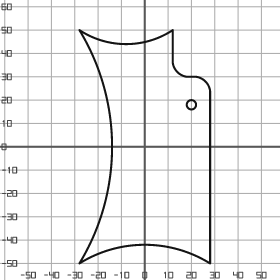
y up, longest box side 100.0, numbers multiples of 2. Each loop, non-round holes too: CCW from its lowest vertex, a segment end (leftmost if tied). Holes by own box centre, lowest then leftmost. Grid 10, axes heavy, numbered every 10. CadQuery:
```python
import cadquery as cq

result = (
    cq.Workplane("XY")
    .moveTo(-28.0, -50.0)
    .threePointArc((0.0, -42.0), (28.0, -50.0))
    .lineTo(28.0, 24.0)
    .threePointArc((26.0, 28.0), (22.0, 30.0))
    .lineTo(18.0, 30.0)
    .threePointArc((14.0, 32.0), (12.0, 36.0))
    .lineTo(12.0, 50.0)
    .threePointArc((-8.0, 44.0), (-28.0, 50.0))
    .threePointArc((-14.0, 0.0), (-28.0, -50.0))
    .close()
    .moveTo(20.0, 18.0)
    .circle(2.0)
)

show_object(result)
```